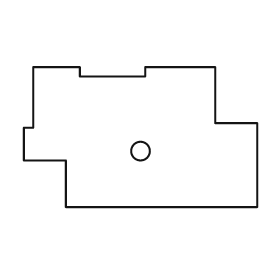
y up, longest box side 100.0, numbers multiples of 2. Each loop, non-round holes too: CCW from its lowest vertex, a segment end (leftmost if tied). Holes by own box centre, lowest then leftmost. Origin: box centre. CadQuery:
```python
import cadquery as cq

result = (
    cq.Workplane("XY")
    .moveTo(-32.0, -30.0)
    .lineTo(50.0, -30.0)
    .lineTo(50.0, 6.0)
    .lineTo(32.0, 6.0)
    .lineTo(32.0, 30.0)
    .lineTo(2.0, 30.0)
    .lineTo(2.0, 26.0)
    .lineTo(-26.0, 26.0)
    .lineTo(-26.0, 30.0)
    .lineTo(-46.0, 30.0)
    .lineTo(-46.0, 4.0)
    .lineTo(-50.0, 4.0)
    .lineTo(-50.0, -10.0)
    .lineTo(-32.0, -10.0)
    .close()
    .moveTo(0.0, -6.0)
    .circle(4.0)
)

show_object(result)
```